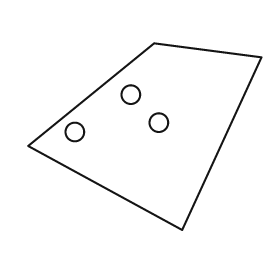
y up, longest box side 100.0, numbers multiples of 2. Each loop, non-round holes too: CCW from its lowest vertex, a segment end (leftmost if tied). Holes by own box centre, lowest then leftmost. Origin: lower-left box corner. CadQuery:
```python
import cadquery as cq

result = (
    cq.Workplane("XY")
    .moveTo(66.0, 0.0)
    .lineTo(100.0, 74.0)
    .lineTo(54.0, 80.0)
    .lineTo(0.0, 36.0)
    .close()
    .moveTo(20.0, 42.0)
    .circle(4.0)
    .moveTo(56.0, 46.0)
    .circle(4.0)
    .moveTo(44.0, 58.0)
    .circle(4.0)
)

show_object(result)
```